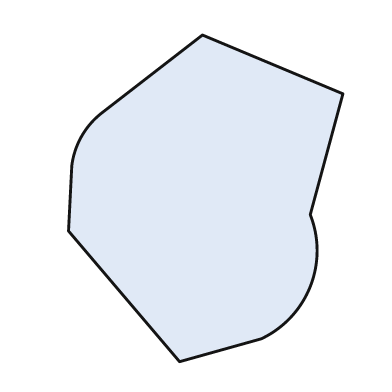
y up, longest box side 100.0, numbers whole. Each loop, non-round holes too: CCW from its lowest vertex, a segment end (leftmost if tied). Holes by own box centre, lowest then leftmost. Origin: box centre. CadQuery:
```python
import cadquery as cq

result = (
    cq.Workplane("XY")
    .moveTo(-8.0, -50.0)
    .lineTo(17.0, -43.0)
    .threePointArc((32.0, -27.0), (32.0, -5.0))
    .lineTo(42.0, 32.0)
    .lineTo(-1.0, 50.0)
    .lineTo(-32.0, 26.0)
    .threePointArc((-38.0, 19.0), (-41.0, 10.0))
    .lineTo(-42.0, -10.0)
    .close()
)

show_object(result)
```